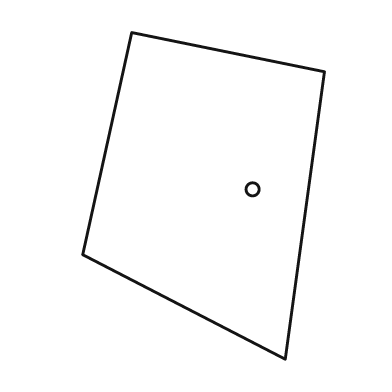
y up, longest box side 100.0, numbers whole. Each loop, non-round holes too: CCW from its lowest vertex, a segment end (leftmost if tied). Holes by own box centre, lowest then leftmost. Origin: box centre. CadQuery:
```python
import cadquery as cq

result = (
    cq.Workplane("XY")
    .moveTo(25.0, -50.0)
    .lineTo(37.0, 38.0)
    .lineTo(-22.0, 50.0)
    .lineTo(-37.0, -18.0)
    .close()
    .moveTo(15.0, 2.0)
    .circle(2.0)
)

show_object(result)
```